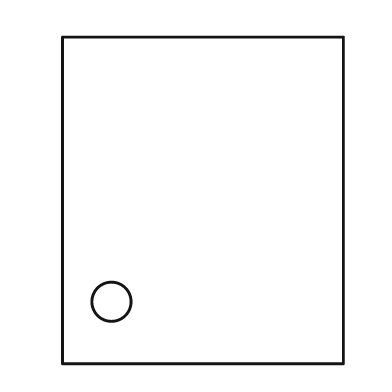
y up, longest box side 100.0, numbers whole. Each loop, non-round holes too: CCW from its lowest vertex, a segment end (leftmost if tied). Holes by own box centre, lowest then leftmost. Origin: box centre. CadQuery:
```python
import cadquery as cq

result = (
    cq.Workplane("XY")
    .moveTo(-43.0, -50.0)
    .lineTo(43.0, -50.0)
    .lineTo(43.0, 50.0)
    .lineTo(-43.0, 50.0)
    .close()
    .moveTo(-28.0, -31.0)
    .circle(6.0)
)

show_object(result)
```